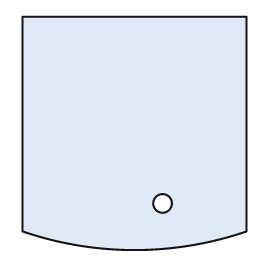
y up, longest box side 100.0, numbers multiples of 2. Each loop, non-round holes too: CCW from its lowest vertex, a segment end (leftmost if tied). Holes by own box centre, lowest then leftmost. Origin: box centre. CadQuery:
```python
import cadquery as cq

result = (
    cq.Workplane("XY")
    .moveTo(-48.0, -42.0)
    .threePointArc((0.0, -50.0), (48.0, -42.0))
    .lineTo(48.0, 50.0)
    .lineTo(-48.0, 50.0)
    .close()
    .moveTo(12.0, -30.0)
    .circle(4.0)
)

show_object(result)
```